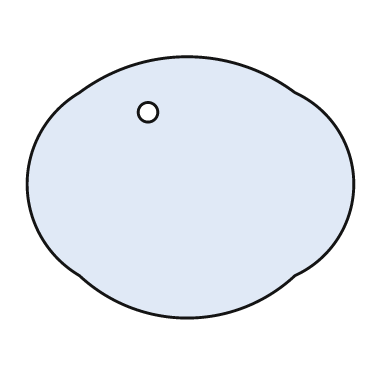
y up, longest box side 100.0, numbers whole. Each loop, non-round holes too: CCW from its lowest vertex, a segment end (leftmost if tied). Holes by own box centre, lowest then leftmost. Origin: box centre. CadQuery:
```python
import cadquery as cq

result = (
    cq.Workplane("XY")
    .moveTo(-34.0, -27.0)
    .threePointArc((-1.0, -40.0), (32.0, -27.0))
    .threePointArc((50.0, 1.0), (32.0, 29.0))
    .threePointArc((-1.0, 40.0), (-34.0, 29.0))
    .threePointArc((-50.0, 1.0), (-34.0, -27.0))
    .close()
    .moveTo(-13.0, 23.0)
    .circle(3.0)
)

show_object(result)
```